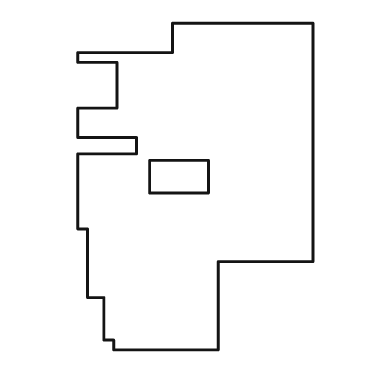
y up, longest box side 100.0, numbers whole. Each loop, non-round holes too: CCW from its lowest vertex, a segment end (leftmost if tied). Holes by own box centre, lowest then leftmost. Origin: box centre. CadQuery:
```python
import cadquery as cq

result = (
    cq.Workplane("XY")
    .moveTo(-25.0, -50.0)
    .lineTo(7.0, -50.0)
    .lineTo(7.0, -23.0)
    .lineTo(36.0, -23.0)
    .lineTo(36.0, 50.0)
    .lineTo(-7.0, 50.0)
    .lineTo(-7.0, 41.0)
    .lineTo(-36.0, 41.0)
    .lineTo(-36.0, 38.0)
    .lineTo(-24.0, 38.0)
    .lineTo(-24.0, 24.0)
    .lineTo(-36.0, 24.0)
    .lineTo(-36.0, 15.0)
    .lineTo(-18.0, 15.0)
    .lineTo(-18.0, 10.0)
    .lineTo(-36.0, 10.0)
    .lineTo(-36.0, -13.0)
    .lineTo(-33.0, -13.0)
    .lineTo(-33.0, -34.0)
    .lineTo(-28.0, -34.0)
    .lineTo(-28.0, -47.0)
    .lineTo(-25.0, -47.0)
    .close()
    .moveTo(-14.0, -2.0)
    .lineTo(4.0, -2.0)
    .lineTo(4.0, 8.0)
    .lineTo(-14.0, 8.0)
    .close()
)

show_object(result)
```